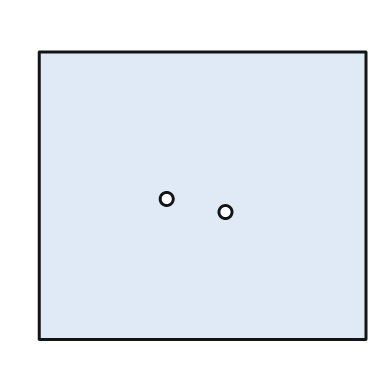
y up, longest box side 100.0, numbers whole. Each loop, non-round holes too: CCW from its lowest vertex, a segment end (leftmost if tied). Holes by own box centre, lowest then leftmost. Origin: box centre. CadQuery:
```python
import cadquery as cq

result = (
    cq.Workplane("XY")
    .moveTo(-50.0, -44.0)
    .lineTo(50.0, -44.0)
    .lineTo(50.0, 44.0)
    .lineTo(-50.0, 44.0)
    .close()
    .moveTo(7.0, -5.0)
    .circle(2.0)
    .moveTo(-11.0, -1.0)
    .circle(2.0)
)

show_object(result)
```